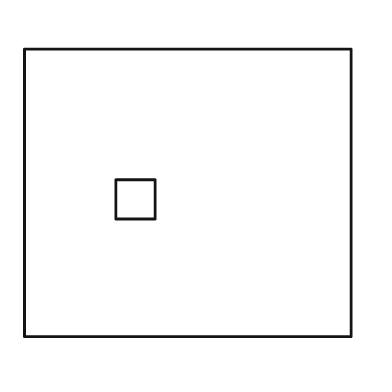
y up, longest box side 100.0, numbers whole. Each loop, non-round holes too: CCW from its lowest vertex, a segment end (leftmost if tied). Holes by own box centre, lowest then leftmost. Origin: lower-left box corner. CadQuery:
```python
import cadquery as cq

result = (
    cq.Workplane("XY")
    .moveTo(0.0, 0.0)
    .lineTo(100.0, 0.0)
    .lineTo(100.0, 88.0)
    .lineTo(0.0, 88.0)
    .close()
    .moveTo(28.0, 36.0)
    .lineTo(40.0, 36.0)
    .lineTo(40.0, 48.0)
    .lineTo(28.0, 48.0)
    .close()
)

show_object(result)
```